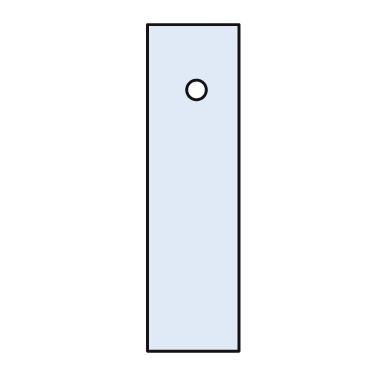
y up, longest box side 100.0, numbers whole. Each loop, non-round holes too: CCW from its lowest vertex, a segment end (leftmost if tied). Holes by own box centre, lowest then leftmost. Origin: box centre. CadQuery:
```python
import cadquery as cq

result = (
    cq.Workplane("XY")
    .moveTo(-14.0, -50.0)
    .lineTo(14.0, -50.0)
    .lineTo(14.0, 50.0)
    .lineTo(-14.0, 50.0)
    .close()
    .moveTo(1.0, 30.0)
    .circle(3.0)
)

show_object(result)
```